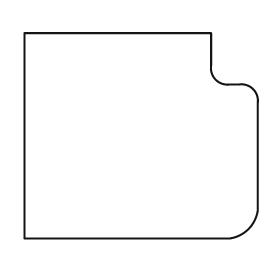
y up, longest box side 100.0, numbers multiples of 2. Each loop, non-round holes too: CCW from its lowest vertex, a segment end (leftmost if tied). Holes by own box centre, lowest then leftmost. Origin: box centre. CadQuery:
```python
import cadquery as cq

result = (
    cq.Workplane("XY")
    .moveTo(-50.0, -44.0)
    .lineTo(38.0, -44.0)
    .threePointArc((46.0, -40.0), (50.0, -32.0))
    .lineTo(50.0, 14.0)
    .threePointArc((48.0, 20.0), (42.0, 22.0))
    .lineTo(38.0, 22.0)
    .threePointArc((32.0, 24.0), (30.0, 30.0))
    .lineTo(30.0, 44.0)
    .lineTo(-50.0, 44.0)
    .close()
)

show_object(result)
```